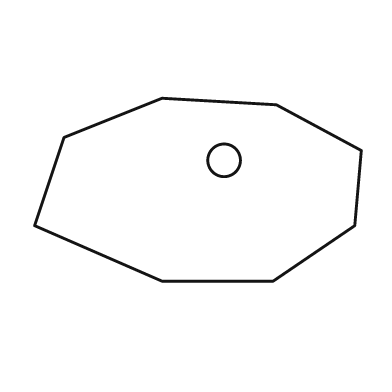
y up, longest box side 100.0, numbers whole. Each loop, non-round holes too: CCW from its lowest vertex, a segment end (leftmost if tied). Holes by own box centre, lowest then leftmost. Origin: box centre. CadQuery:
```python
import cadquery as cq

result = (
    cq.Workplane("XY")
    .moveTo(-11.0, -28.0)
    .lineTo(23.0, -28.0)
    .lineTo(48.0, -11.0)
    .lineTo(50.0, 12.0)
    .lineTo(24.0, 26.0)
    .lineTo(-11.0, 28.0)
    .lineTo(-41.0, 16.0)
    .lineTo(-50.0, -11.0)
    .close()
    .moveTo(8.0, 9.0)
    .circle(5.0)
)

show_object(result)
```